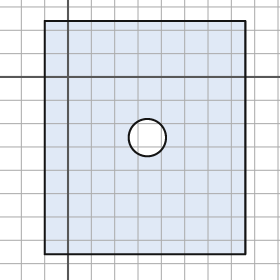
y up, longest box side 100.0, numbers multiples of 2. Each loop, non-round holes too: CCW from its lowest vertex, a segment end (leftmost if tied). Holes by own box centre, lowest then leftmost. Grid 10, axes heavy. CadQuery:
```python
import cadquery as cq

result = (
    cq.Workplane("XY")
    .moveTo(-10.0, -76.0)
    .lineTo(76.0, -76.0)
    .lineTo(76.0, 24.0)
    .lineTo(-10.0, 24.0)
    .close()
    .moveTo(34.0, -26.0)
    .circle(8.0)
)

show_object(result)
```